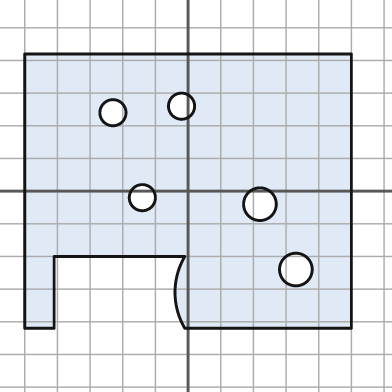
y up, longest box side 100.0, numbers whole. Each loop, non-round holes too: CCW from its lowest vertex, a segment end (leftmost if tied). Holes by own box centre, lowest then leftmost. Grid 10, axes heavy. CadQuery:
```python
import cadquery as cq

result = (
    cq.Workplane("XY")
    .moveTo(-50.0, -42.0)
    .lineTo(-41.0, -42.0)
    .lineTo(-41.0, -20.0)
    .lineTo(-1.0, -20.0)
    .threePointArc((-4.0, -31.0), (-1.0, -42.0))
    .lineTo(50.0, -42.0)
    .lineTo(50.0, 42.0)
    .lineTo(-50.0, 42.0)
    .close()
    .moveTo(33.0, -24.0)
    .circle(5.0)
    .moveTo(22.0, -4.0)
    .circle(5.0)
    .moveTo(-14.0, -2.0)
    .circle(4.0)
    .moveTo(-23.0, 24.0)
    .circle(4.0)
    .moveTo(-2.0, 26.0)
    .circle(4.0)
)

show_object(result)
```